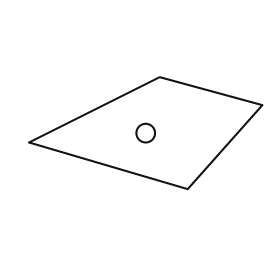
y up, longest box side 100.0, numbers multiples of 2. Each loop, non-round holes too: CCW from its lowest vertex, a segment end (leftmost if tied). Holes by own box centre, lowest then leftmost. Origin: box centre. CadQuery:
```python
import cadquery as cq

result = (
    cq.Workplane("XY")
    .moveTo(18.0, -24.0)
    .lineTo(50.0, 12.0)
    .lineTo(6.0, 24.0)
    .lineTo(-50.0, -4.0)
    .close()
    .moveTo(0.0, 0.0)
    .circle(4.0)
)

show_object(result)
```